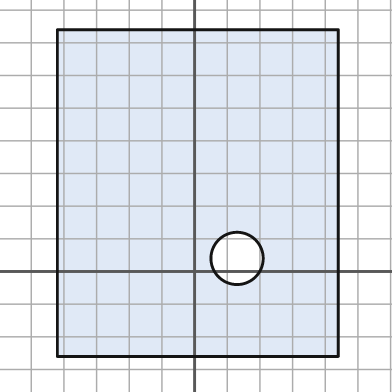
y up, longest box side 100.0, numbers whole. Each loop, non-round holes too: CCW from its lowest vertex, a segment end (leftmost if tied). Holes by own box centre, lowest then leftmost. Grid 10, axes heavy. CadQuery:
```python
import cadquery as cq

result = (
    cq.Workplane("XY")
    .moveTo(-42.0, -26.0)
    .lineTo(44.0, -26.0)
    .lineTo(44.0, 74.0)
    .lineTo(-42.0, 74.0)
    .close()
    .moveTo(13.0, 4.0)
    .circle(8.0)
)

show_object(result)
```